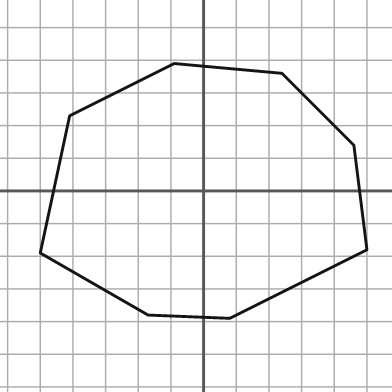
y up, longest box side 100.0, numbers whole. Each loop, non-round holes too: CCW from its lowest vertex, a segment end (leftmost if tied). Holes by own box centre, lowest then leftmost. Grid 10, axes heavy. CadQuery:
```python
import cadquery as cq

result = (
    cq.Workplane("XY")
    .moveTo(8.0, -39.0)
    .lineTo(50.0, -18.0)
    .lineTo(46.0, 14.0)
    .lineTo(24.0, 36.0)
    .lineTo(-9.0, 39.0)
    .lineTo(-41.0, 23.0)
    .lineTo(-50.0, -19.0)
    .lineTo(-17.0, -38.0)
    .close()
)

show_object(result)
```